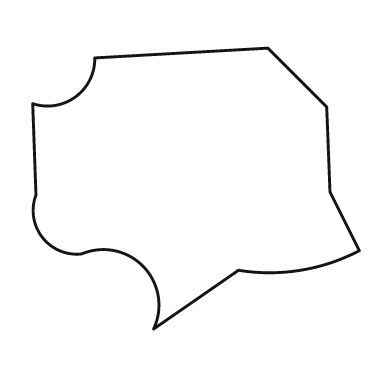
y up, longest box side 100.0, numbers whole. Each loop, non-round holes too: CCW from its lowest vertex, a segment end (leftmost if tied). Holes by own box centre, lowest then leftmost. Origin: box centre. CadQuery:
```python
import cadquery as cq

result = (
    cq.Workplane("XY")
    .moveTo(-13.0, -43.0)
    .lineTo(13.0, -25.0)
    .threePointArc((32.0, -25.0), (50.0, -19.0))
    .lineTo(41.0, -1.0)
    .lineTo(40.0, 25.0)
    .lineTo(22.0, 43.0)
    .lineTo(-31.0, 40.0)
    .threePointArc((-37.0, 28.0), (-50.0, 26.0))
    .lineTo(-49.0, -2.0)
    .threePointArc((-47.0, -15.0), (-35.0, -20.0))
    .threePointArc((-16.0, -24.0), (-13.0, -43.0))
    .close()
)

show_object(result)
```